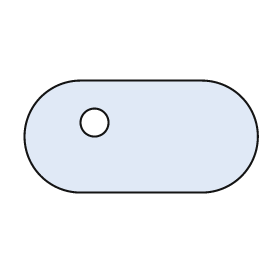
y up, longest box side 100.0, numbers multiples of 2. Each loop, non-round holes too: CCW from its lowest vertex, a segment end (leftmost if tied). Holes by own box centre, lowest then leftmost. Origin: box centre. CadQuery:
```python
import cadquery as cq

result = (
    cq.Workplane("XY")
    .moveTo(-26.0, -24.0)
    .lineTo(26.0, -24.0)
    .threePointArc((50.0, 0.0), (26.0, 24.0))
    .lineTo(-26.0, 24.0)
    .threePointArc((-50.0, 0.0), (-26.0, -24.0))
    .close()
    .moveTo(-20.0, 6.0)
    .circle(6.0)
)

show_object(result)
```